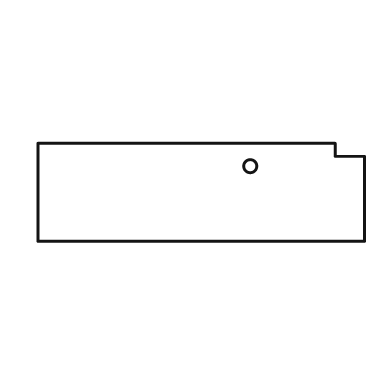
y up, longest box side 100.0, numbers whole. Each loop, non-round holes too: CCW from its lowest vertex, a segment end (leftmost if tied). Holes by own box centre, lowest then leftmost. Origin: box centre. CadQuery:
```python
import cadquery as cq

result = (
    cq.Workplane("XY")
    .moveTo(-50.0, -15.0)
    .lineTo(50.0, -15.0)
    .lineTo(50.0, 11.0)
    .lineTo(41.0, 11.0)
    .lineTo(41.0, 15.0)
    .lineTo(-50.0, 15.0)
    .close()
    .moveTo(15.0, 8.0)
    .circle(2.0)
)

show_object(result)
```